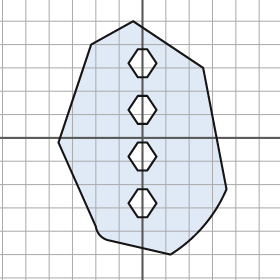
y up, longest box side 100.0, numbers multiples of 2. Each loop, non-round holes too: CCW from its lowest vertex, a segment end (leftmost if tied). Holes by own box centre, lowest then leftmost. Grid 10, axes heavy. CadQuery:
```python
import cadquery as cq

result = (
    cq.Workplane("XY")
    .moveTo(12.0, -50.0)
    .threePointArc((26.0, -38.0), (36.0, -22.0))
    .lineTo(26.0, 30.0)
    .lineTo(-4.0, 50.0)
    .lineTo(-22.0, 40.0)
    .lineTo(-36.0, -2.0)
    .lineTo(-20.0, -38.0)
    .threePointArc((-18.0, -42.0), (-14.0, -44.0))
    .close()
    .moveTo(-2.0, -34.0)
    .lineTo(2.0, -34.0)
    .lineTo(6.0, -28.0)
    .lineTo(2.0, -22.0)
    .lineTo(-2.0, -22.0)
    .lineTo(-6.0, -28.0)
    .close()
    .moveTo(-2.0, -14.0)
    .lineTo(2.0, -14.0)
    .lineTo(6.0, -8.0)
    .lineTo(2.0, -2.0)
    .lineTo(-2.0, -2.0)
    .lineTo(-6.0, -8.0)
    .close()
    .moveTo(-2.0, 6.0)
    .lineTo(2.0, 6.0)
    .lineTo(6.0, 12.0)
    .lineTo(2.0, 18.0)
    .lineTo(-2.0, 18.0)
    .lineTo(-6.0, 12.0)
    .close()
    .moveTo(-2.0, 26.0)
    .lineTo(2.0, 26.0)
    .lineTo(6.0, 32.0)
    .lineTo(2.0, 38.0)
    .lineTo(-2.0, 38.0)
    .lineTo(-6.0, 32.0)
    .close()
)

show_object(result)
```